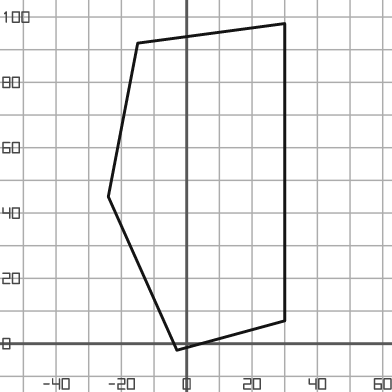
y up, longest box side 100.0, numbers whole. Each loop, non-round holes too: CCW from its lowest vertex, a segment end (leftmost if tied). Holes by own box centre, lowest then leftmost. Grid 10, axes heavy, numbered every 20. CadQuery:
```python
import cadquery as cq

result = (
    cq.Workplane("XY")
    .moveTo(-3.0, -2.0)
    .lineTo(30.0, 7.0)
    .lineTo(30.0, 98.0)
    .lineTo(-15.0, 92.0)
    .lineTo(-24.0, 45.0)
    .close()
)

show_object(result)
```